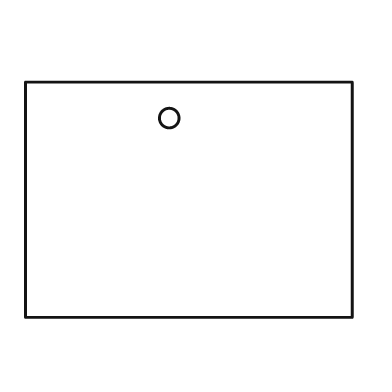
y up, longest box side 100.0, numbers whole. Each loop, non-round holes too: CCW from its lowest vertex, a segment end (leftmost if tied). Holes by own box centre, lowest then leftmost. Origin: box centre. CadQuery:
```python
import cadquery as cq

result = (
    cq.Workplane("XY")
    .moveTo(-50.0, -36.0)
    .lineTo(50.0, -36.0)
    .lineTo(50.0, 36.0)
    .lineTo(-50.0, 36.0)
    .close()
    .moveTo(-6.0, 25.0)
    .circle(3.0)
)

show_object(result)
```